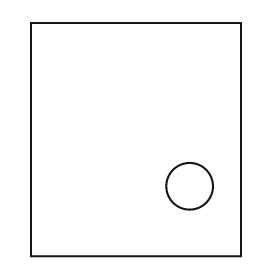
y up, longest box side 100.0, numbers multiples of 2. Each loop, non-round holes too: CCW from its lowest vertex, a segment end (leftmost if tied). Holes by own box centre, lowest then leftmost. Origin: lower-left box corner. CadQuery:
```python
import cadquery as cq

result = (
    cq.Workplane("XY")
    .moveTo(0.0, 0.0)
    .lineTo(90.0, 0.0)
    .lineTo(90.0, 100.0)
    .lineTo(0.0, 100.0)
    .close()
    .moveTo(68.0, 30.0)
    .circle(10.0)
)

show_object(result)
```